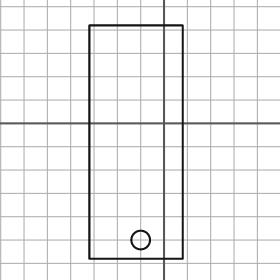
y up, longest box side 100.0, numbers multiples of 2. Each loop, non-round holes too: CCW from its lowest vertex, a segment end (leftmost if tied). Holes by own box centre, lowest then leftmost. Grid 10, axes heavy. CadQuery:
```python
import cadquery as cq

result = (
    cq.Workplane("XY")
    .moveTo(-32.0, -58.0)
    .lineTo(8.0, -58.0)
    .lineTo(8.0, 42.0)
    .lineTo(-32.0, 42.0)
    .close()
    .moveTo(-10.0, -50.0)
    .circle(4.0)
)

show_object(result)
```